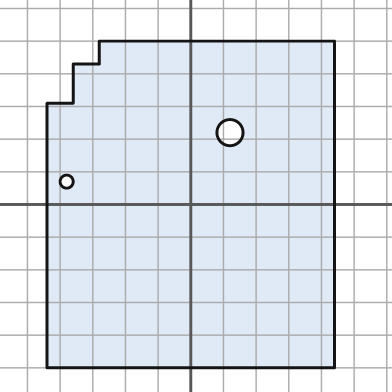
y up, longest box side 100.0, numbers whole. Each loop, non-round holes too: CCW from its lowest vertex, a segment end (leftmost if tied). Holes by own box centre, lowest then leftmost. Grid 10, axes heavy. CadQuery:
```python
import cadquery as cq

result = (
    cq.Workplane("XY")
    .moveTo(-44.0, -50.0)
    .lineTo(44.0, -50.0)
    .lineTo(44.0, 50.0)
    .lineTo(-28.0, 50.0)
    .lineTo(-28.0, 43.0)
    .lineTo(-36.0, 43.0)
    .lineTo(-36.0, 31.0)
    .lineTo(-44.0, 31.0)
    .close()
    .moveTo(-38.0, 7.0)
    .circle(2.0)
    .moveTo(12.0, 22.0)
    .circle(4.0)
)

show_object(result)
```